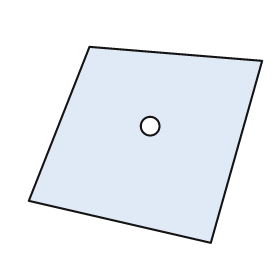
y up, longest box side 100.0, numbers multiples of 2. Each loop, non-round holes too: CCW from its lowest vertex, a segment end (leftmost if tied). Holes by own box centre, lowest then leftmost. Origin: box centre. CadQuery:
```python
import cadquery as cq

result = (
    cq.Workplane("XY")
    .moveTo(28.0, -42.0)
    .lineTo(50.0, 36.0)
    .lineTo(-24.0, 42.0)
    .lineTo(-50.0, -24.0)
    .close()
    .moveTo(2.0, 8.0)
    .circle(4.0)
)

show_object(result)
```